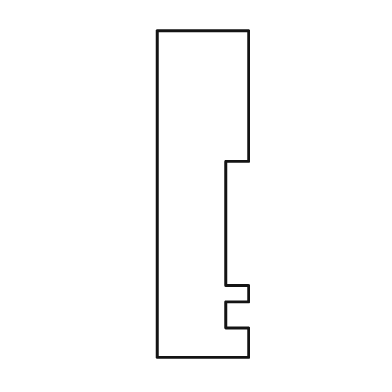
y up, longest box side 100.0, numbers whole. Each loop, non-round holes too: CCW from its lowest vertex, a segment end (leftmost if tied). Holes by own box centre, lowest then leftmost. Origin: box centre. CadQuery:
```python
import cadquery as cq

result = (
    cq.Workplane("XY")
    .moveTo(-14.0, -50.0)
    .lineTo(14.0, -50.0)
    .lineTo(14.0, -41.0)
    .lineTo(7.0, -41.0)
    .lineTo(7.0, -33.0)
    .lineTo(14.0, -33.0)
    .lineTo(14.0, -28.0)
    .lineTo(7.0, -28.0)
    .lineTo(7.0, 10.0)
    .lineTo(14.0, 10.0)
    .lineTo(14.0, 50.0)
    .lineTo(-14.0, 50.0)
    .close()
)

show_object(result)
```